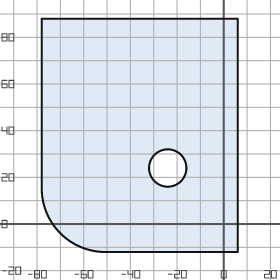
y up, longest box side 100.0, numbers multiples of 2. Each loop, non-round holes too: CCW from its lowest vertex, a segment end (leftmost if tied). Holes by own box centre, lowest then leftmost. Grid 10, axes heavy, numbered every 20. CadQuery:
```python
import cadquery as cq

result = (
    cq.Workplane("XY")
    .moveTo(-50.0, -12.0)
    .lineTo(6.0, -12.0)
    .lineTo(6.0, 88.0)
    .lineTo(-78.0, 88.0)
    .lineTo(-78.0, 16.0)
    .threePointArc((-70.0, -4.0), (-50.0, -12.0))
    .close()
    .moveTo(-24.0, 24.0)
    .circle(8.0)
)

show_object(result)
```